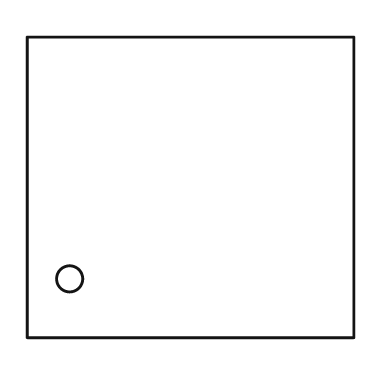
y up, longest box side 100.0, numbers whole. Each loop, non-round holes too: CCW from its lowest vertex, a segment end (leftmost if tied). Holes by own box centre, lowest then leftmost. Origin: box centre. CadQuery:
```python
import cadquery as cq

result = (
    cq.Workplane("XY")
    .moveTo(-50.0, -46.0)
    .lineTo(50.0, -46.0)
    .lineTo(50.0, 46.0)
    .lineTo(-50.0, 46.0)
    .close()
    .moveTo(-37.0, -28.0)
    .circle(4.0)
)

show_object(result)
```